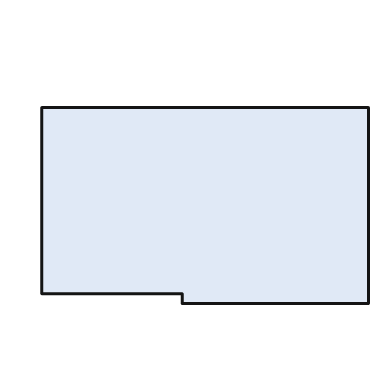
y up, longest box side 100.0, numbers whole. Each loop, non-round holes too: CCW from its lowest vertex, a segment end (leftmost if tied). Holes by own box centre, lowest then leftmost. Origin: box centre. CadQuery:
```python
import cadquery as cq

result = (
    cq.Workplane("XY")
    .moveTo(-7.0, -30.0)
    .lineTo(50.0, -30.0)
    .lineTo(50.0, 30.0)
    .lineTo(-50.0, 30.0)
    .lineTo(-50.0, -27.0)
    .lineTo(-7.0, -27.0)
    .close()
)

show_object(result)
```